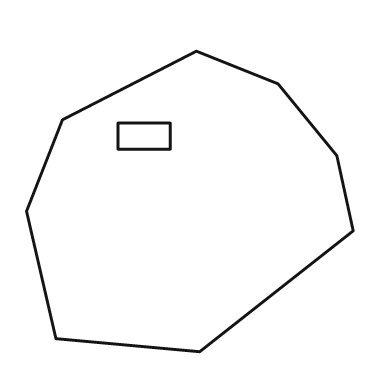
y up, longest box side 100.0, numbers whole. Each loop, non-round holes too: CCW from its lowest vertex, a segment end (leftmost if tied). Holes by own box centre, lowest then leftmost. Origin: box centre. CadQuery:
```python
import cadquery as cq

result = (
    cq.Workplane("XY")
    .moveTo(3.0, -46.0)
    .lineTo(50.0, -9.0)
    .lineTo(45.0, 14.0)
    .lineTo(27.0, 36.0)
    .lineTo(2.0, 46.0)
    .lineTo(-39.0, 25.0)
    .lineTo(-50.0, -3.0)
    .lineTo(-41.0, -42.0)
    .close()
    .moveTo(-22.0, 16.0)
    .lineTo(-6.0, 16.0)
    .lineTo(-6.0, 24.0)
    .lineTo(-22.0, 24.0)
    .close()
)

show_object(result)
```